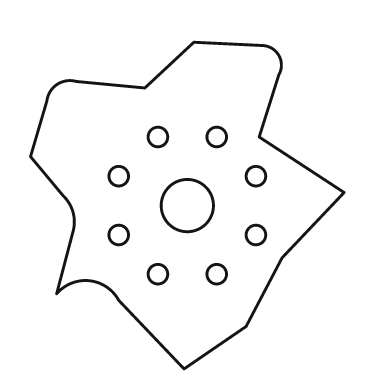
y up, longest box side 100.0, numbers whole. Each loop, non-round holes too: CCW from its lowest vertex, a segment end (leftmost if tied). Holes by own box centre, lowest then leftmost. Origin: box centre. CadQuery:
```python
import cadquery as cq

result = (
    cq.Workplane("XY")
    .moveTo(-1.0, -50.0)
    .lineTo(18.0, -37.0)
    .lineTo(29.0, -16.0)
    .lineTo(48.0, 4.0)
    .lineTo(22.0, 21.0)
    .lineTo(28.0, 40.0)
    .threePointArc((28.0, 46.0), (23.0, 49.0))
    .lineTo(2.0, 50.0)
    .lineTo(-13.0, 36.0)
    .lineTo(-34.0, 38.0)
    .threePointArc((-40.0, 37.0), (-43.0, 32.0))
    .lineTo(-48.0, 15.0)
    .lineTo(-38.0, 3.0)
    .threePointArc((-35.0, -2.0), (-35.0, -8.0))
    .lineTo(-40.0, -27.0)
    .threePointArc((-30.0, -23.0), (-21.0, -29.0))
    .close()
    .moveTo(-9.0, -21.0)
    .circle(3.0)
    .moveTo(9.0, -21.0)
    .circle(3.0)
    .moveTo(-21.0, -9.0)
    .circle(3.0)
    .moveTo(21.0, -9.0)
    .circle(3.0)
    .moveTo(0.0, 0.0)
    .circle(8.0)
    .moveTo(-21.0, 9.0)
    .circle(3.0)
    .moveTo(21.0, 9.0)
    .circle(3.0)
    .moveTo(-9.0, 21.0)
    .circle(3.0)
    .moveTo(9.0, 21.0)
    .circle(3.0)
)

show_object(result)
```